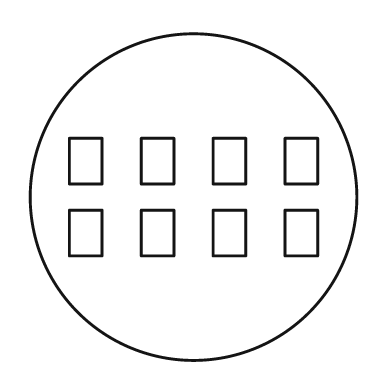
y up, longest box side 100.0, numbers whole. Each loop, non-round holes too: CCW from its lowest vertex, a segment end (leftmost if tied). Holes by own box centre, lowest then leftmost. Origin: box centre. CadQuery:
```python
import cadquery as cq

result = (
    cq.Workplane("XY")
    .moveTo(0.0, 0.0)
    .circle(50.0)
    .moveTo(-38.0, -18.0)
    .lineTo(-28.0, -18.0)
    .lineTo(-28.0, -4.0)
    .lineTo(-38.0, -4.0)
    .close()
    .moveTo(-16.0, -18.0)
    .lineTo(-6.0, -18.0)
    .lineTo(-6.0, -4.0)
    .lineTo(-16.0, -4.0)
    .close()
    .moveTo(6.0, -18.0)
    .lineTo(16.0, -18.0)
    .lineTo(16.0, -4.0)
    .lineTo(6.0, -4.0)
    .close()
    .moveTo(28.0, -18.0)
    .lineTo(38.0, -18.0)
    .lineTo(38.0, -4.0)
    .lineTo(28.0, -4.0)
    .close()
    .moveTo(-38.0, 4.0)
    .lineTo(-28.0, 4.0)
    .lineTo(-28.0, 18.0)
    .lineTo(-38.0, 18.0)
    .close()
    .moveTo(-16.0, 4.0)
    .lineTo(-6.0, 4.0)
    .lineTo(-6.0, 18.0)
    .lineTo(-16.0, 18.0)
    .close()
    .moveTo(6.0, 4.0)
    .lineTo(16.0, 4.0)
    .lineTo(16.0, 18.0)
    .lineTo(6.0, 18.0)
    .close()
    .moveTo(28.0, 4.0)
    .lineTo(38.0, 4.0)
    .lineTo(38.0, 18.0)
    .lineTo(28.0, 18.0)
    .close()
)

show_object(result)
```